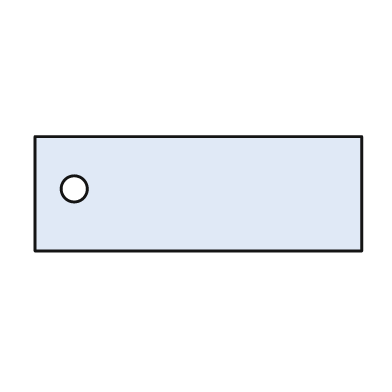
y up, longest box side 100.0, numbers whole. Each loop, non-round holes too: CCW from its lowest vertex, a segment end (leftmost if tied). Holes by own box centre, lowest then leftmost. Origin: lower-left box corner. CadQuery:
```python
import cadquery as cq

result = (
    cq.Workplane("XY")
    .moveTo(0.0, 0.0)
    .lineTo(100.0, 0.0)
    .lineTo(100.0, 35.0)
    .lineTo(0.0, 35.0)
    .close()
    .moveTo(12.0, 19.0)
    .circle(4.0)
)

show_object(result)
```